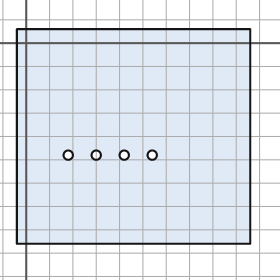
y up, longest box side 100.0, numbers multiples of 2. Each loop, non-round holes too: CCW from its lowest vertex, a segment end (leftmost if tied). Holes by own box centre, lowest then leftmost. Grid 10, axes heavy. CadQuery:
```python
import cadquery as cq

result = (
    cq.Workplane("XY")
    .moveTo(-4.0, -86.0)
    .lineTo(96.0, -86.0)
    .lineTo(96.0, 6.0)
    .lineTo(-4.0, 6.0)
    .close()
    .moveTo(18.0, -48.0)
    .circle(2.0)
    .moveTo(30.0, -48.0)
    .circle(2.0)
    .moveTo(42.0, -48.0)
    .circle(2.0)
    .moveTo(54.0, -48.0)
    .circle(2.0)
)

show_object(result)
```